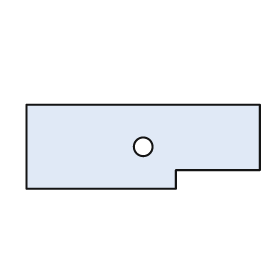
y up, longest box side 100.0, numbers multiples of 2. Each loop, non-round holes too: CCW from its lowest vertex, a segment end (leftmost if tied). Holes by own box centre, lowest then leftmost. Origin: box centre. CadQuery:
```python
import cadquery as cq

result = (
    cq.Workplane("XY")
    .moveTo(-50.0, -18.0)
    .lineTo(14.0, -18.0)
    .lineTo(14.0, -10.0)
    .lineTo(50.0, -10.0)
    .lineTo(50.0, 18.0)
    .lineTo(-50.0, 18.0)
    .close()
    .moveTo(0.0, 0.0)
    .circle(4.0)
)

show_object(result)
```